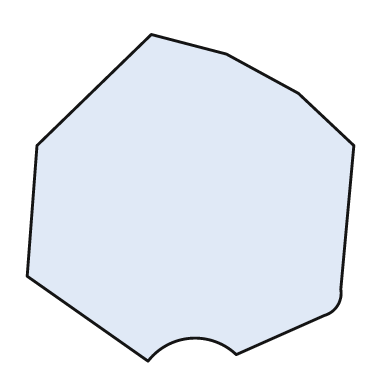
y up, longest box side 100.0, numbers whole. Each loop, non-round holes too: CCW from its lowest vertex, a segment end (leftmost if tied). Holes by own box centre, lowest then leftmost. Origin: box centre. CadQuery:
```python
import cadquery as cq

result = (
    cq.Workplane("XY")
    .moveTo(-13.0, -50.0)
    .threePointArc((0.0, -43.0), (14.0, -48.0))
    .lineTo(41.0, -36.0)
    .threePointArc((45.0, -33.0), (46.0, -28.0))
    .lineTo(50.0, 16.0)
    .lineTo(33.0, 32.0)
    .lineTo(11.0, 44.0)
    .lineTo(-12.0, 50.0)
    .lineTo(-47.0, 16.0)
    .lineTo(-50.0, -24.0)
    .close()
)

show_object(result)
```